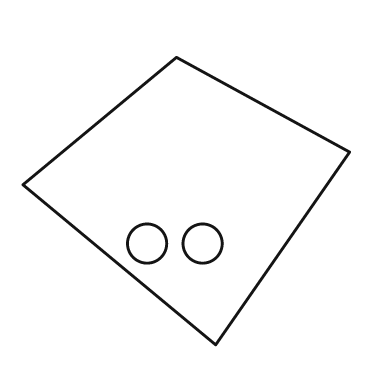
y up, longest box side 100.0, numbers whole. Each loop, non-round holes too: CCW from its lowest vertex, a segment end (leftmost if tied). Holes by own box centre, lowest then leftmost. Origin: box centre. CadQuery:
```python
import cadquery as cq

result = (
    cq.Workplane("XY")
    .moveTo(9.0, -44.0)
    .lineTo(50.0, 15.0)
    .lineTo(-3.0, 44.0)
    .lineTo(-50.0, 5.0)
    .close()
    .moveTo(-12.0, -13.0)
    .circle(6.0)
    .moveTo(5.0, -13.0)
    .circle(6.0)
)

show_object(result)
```